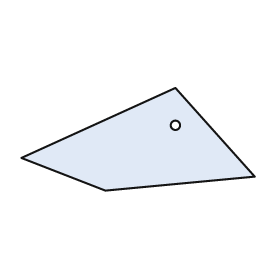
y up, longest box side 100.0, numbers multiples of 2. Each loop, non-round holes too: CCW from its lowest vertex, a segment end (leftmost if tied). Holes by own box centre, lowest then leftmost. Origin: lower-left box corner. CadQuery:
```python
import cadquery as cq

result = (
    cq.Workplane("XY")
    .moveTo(36.0, 0.0)
    .lineTo(100.0, 6.0)
    .lineTo(66.0, 44.0)
    .lineTo(0.0, 14.0)
    .close()
    .moveTo(66.0, 28.0)
    .circle(2.0)
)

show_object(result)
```